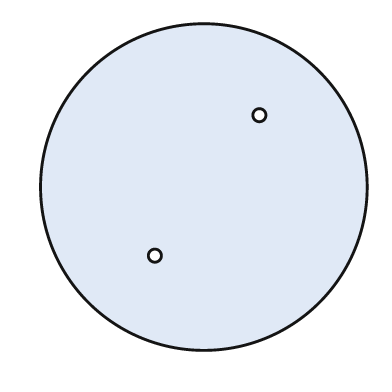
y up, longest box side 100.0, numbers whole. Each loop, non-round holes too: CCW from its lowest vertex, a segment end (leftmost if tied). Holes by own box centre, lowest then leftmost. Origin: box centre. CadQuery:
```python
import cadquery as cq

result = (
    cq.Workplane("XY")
    .moveTo(0.0, 0.0)
    .circle(50.0)
    .moveTo(-15.0, -21.0)
    .circle(2.0)
    .moveTo(17.0, 22.0)
    .circle(2.0)
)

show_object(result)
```